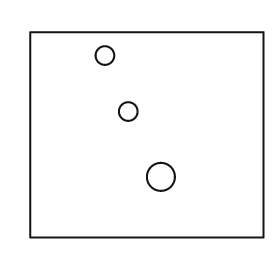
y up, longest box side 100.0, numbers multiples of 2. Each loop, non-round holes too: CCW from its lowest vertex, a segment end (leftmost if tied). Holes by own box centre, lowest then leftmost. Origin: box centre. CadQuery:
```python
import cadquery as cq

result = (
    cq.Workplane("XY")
    .moveTo(-50.0, -44.0)
    .lineTo(50.0, -44.0)
    .lineTo(50.0, 44.0)
    .lineTo(-50.0, 44.0)
    .close()
    .moveTo(6.0, -18.0)
    .circle(6.0)
    .moveTo(-8.0, 10.0)
    .circle(4.0)
    .moveTo(-18.0, 34.0)
    .circle(4.0)
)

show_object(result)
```